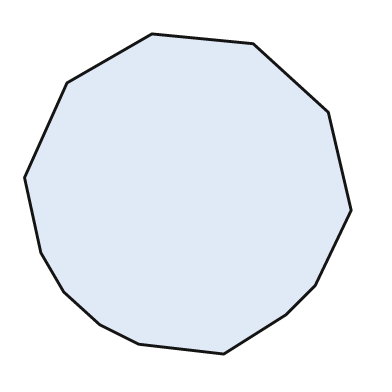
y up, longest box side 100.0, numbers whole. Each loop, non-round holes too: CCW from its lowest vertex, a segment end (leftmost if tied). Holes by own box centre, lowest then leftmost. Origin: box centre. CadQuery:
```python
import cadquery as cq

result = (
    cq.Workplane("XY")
    .moveTo(11.0, -49.0)
    .lineTo(30.0, -37.0)
    .lineTo(39.0, -28.0)
    .lineTo(50.0, -5.0)
    .lineTo(43.0, 25.0)
    .lineTo(20.0, 46.0)
    .lineTo(-11.0, 49.0)
    .lineTo(-37.0, 34.0)
    .lineTo(-50.0, 5.0)
    .lineTo(-45.0, -18.0)
    .lineTo(-38.0, -30.0)
    .lineTo(-27.0, -40.0)
    .lineTo(-15.0, -46.0)
    .close()
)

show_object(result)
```